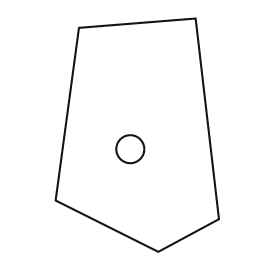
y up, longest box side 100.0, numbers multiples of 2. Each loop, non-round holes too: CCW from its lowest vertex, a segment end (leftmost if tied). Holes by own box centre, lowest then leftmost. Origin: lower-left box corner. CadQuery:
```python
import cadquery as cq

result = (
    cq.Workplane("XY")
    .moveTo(44.0, 0.0)
    .lineTo(70.0, 14.0)
    .lineTo(60.0, 100.0)
    .lineTo(10.0, 96.0)
    .lineTo(0.0, 22.0)
    .close()
    .moveTo(32.0, 44.0)
    .circle(6.0)
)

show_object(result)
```